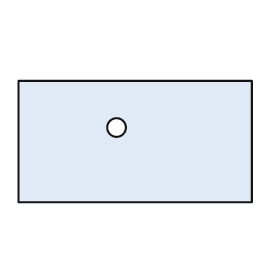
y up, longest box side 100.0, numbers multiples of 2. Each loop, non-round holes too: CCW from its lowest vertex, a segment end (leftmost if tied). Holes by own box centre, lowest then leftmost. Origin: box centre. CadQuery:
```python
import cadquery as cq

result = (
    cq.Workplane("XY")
    .moveTo(-50.0, -26.0)
    .lineTo(50.0, -26.0)
    .lineTo(50.0, 26.0)
    .lineTo(-50.0, 26.0)
    .close()
    .moveTo(-8.0, 6.0)
    .circle(4.0)
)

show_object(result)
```